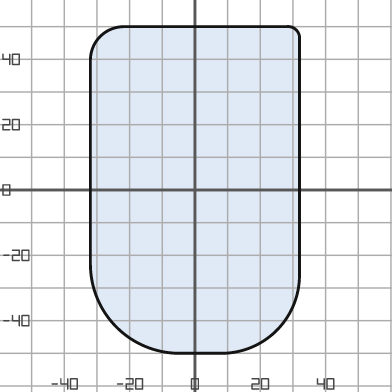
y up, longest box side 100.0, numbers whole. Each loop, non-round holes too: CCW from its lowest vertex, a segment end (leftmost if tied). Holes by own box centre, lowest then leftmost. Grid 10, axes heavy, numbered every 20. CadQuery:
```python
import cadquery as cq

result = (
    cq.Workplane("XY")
    .moveTo(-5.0, -50.0)
    .lineTo(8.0, -50.0)
    .threePointArc((25.0, -43.0), (32.0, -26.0))
    .lineTo(32.0, 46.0)
    .threePointArc((31.0, 49.0), (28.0, 50.0))
    .lineTo(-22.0, 50.0)
    .threePointArc((-29.0, 47.0), (-32.0, 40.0))
    .lineTo(-32.0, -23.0)
    .threePointArc((-24.0, -42.0), (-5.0, -50.0))
    .close()
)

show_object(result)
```